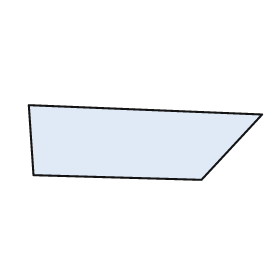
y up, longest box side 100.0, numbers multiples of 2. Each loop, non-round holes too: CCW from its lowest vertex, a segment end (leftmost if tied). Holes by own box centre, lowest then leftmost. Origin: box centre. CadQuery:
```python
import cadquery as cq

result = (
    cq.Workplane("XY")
    .moveTo(24.0, -16.0)
    .lineTo(50.0, 12.0)
    .lineTo(-50.0, 16.0)
    .lineTo(-48.0, -14.0)
    .close()
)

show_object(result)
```